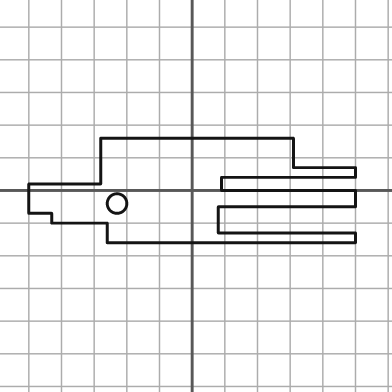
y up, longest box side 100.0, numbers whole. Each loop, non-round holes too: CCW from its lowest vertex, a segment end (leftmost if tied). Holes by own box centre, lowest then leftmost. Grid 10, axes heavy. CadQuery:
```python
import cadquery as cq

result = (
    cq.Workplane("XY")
    .moveTo(-26.0, -16.0)
    .lineTo(50.0, -16.0)
    .lineTo(50.0, -13.0)
    .lineTo(8.0, -13.0)
    .lineTo(8.0, -5.0)
    .lineTo(50.0, -5.0)
    .lineTo(50.0, 0.0)
    .lineTo(9.0, 0.0)
    .lineTo(9.0, 4.0)
    .lineTo(50.0, 4.0)
    .lineTo(50.0, 7.0)
    .lineTo(31.0, 7.0)
    .lineTo(31.0, 16.0)
    .lineTo(-28.0, 16.0)
    .lineTo(-28.0, 2.0)
    .lineTo(-50.0, 2.0)
    .lineTo(-50.0, -7.0)
    .lineTo(-43.0, -7.0)
    .lineTo(-43.0, -10.0)
    .lineTo(-26.0, -10.0)
    .close()
    .moveTo(-23.0, -4.0)
    .circle(3.0)
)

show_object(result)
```